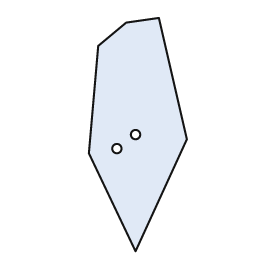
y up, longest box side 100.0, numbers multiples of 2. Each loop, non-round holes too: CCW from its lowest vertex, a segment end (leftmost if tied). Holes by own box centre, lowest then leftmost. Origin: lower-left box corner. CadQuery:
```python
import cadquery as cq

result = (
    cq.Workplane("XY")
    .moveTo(20.0, 0.0)
    .lineTo(42.0, 48.0)
    .lineTo(30.0, 100.0)
    .lineTo(16.0, 98.0)
    .lineTo(4.0, 88.0)
    .lineTo(0.0, 42.0)
    .close()
    .moveTo(12.0, 44.0)
    .circle(2.0)
    .moveTo(20.0, 50.0)
    .circle(2.0)
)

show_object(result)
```